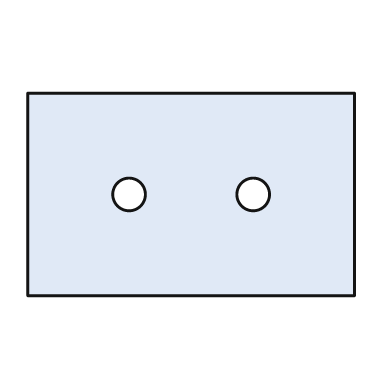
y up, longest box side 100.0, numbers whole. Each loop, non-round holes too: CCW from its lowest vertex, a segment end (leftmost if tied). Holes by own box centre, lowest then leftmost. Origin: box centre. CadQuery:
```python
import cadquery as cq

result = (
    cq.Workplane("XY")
    .moveTo(-50.0, -31.0)
    .lineTo(50.0, -31.0)
    .lineTo(50.0, 31.0)
    .lineTo(-50.0, 31.0)
    .close()
    .moveTo(-19.0, 0.0)
    .circle(5.0)
    .moveTo(19.0, 0.0)
    .circle(5.0)
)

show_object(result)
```